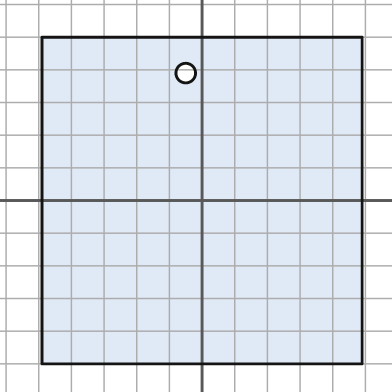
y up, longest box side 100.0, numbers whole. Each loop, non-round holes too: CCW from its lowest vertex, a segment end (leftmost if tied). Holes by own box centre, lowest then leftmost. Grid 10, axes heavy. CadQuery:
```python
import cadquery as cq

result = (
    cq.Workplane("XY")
    .moveTo(-49.0, -50.0)
    .lineTo(49.0, -50.0)
    .lineTo(49.0, 50.0)
    .lineTo(-49.0, 50.0)
    .close()
    .moveTo(-5.0, 39.0)
    .circle(3.0)
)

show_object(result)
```